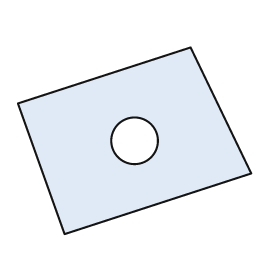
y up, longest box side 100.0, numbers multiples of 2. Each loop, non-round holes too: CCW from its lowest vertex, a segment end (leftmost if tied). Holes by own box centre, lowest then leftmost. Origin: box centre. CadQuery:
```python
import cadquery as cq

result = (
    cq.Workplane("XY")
    .moveTo(-30.0, -40.0)
    .lineTo(50.0, -14.0)
    .lineTo(24.0, 40.0)
    .lineTo(-50.0, 16.0)
    .close()
    .moveTo(0.0, 0.0)
    .circle(10.0)
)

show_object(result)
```